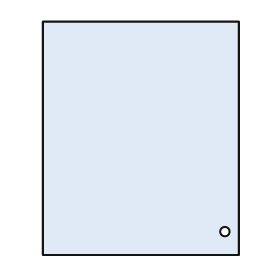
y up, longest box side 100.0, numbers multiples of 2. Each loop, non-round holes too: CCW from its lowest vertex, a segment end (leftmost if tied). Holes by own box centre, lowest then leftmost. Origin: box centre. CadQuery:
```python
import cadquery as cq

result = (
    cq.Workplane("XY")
    .moveTo(-42.0, -50.0)
    .lineTo(42.0, -50.0)
    .lineTo(42.0, 50.0)
    .lineTo(-42.0, 50.0)
    .close()
    .moveTo(36.0, -40.0)
    .circle(2.0)
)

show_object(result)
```